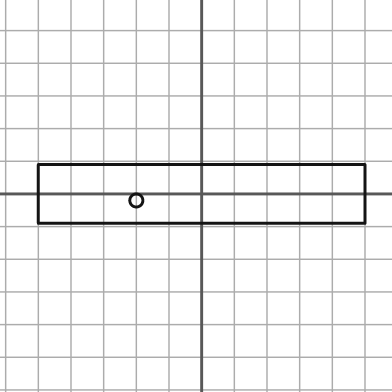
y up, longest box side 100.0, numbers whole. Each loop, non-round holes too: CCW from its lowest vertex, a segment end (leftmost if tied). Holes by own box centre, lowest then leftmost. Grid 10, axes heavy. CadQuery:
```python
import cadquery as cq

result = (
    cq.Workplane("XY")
    .moveTo(-50.0, -9.0)
    .lineTo(50.0, -9.0)
    .lineTo(50.0, 9.0)
    .lineTo(-50.0, 9.0)
    .close()
    .moveTo(-20.0, -2.0)
    .circle(2.0)
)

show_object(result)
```